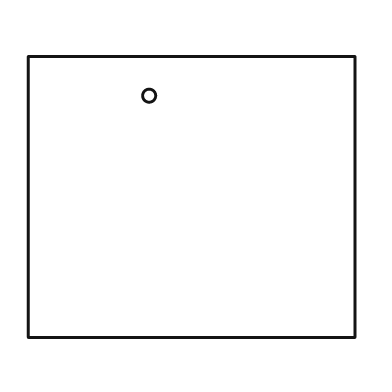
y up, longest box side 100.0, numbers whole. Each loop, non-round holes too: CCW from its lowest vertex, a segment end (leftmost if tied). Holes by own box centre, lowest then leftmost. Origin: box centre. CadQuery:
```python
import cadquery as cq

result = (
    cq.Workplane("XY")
    .moveTo(-50.0, -43.0)
    .lineTo(50.0, -43.0)
    .lineTo(50.0, 43.0)
    .lineTo(-50.0, 43.0)
    .close()
    .moveTo(-13.0, 31.0)
    .circle(2.0)
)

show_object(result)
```